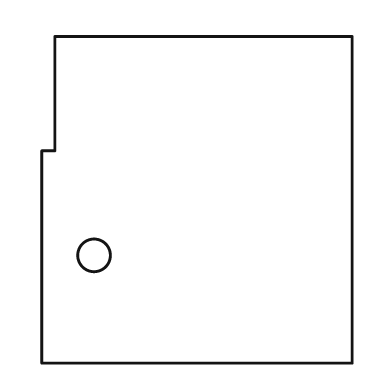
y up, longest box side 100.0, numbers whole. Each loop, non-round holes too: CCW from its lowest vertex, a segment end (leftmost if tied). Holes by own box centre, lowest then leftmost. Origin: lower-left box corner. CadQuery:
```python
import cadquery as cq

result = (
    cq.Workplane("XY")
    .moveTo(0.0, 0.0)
    .lineTo(95.0, 0.0)
    .lineTo(95.0, 100.0)
    .lineTo(4.0, 100.0)
    .lineTo(4.0, 65.0)
    .lineTo(0.0, 65.0)
    .close()
    .moveTo(16.0, 33.0)
    .circle(5.0)
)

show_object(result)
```